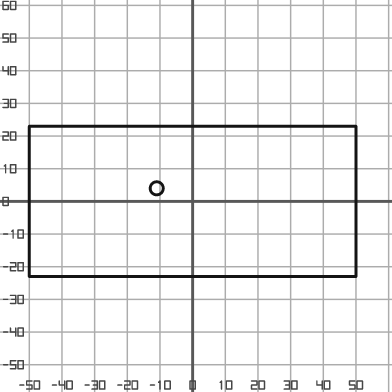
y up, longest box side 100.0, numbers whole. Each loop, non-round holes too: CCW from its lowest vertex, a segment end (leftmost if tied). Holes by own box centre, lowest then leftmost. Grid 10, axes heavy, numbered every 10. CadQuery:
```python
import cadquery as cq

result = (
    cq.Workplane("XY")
    .moveTo(-50.0, -23.0)
    .lineTo(50.0, -23.0)
    .lineTo(50.0, 23.0)
    .lineTo(-50.0, 23.0)
    .close()
    .moveTo(-11.0, 4.0)
    .circle(2.0)
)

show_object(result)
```